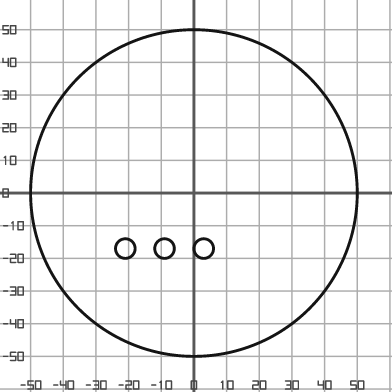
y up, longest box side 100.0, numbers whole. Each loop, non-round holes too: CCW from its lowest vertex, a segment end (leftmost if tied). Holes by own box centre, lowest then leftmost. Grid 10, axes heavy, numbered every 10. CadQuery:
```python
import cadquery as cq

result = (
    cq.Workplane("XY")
    .moveTo(0.0, 0.0)
    .circle(50.0)
    .moveTo(-21.0, -17.0)
    .circle(3.0)
    .moveTo(-9.0, -17.0)
    .circle(3.0)
    .moveTo(3.0, -17.0)
    .circle(3.0)
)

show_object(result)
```